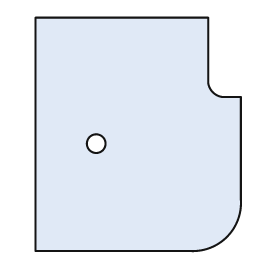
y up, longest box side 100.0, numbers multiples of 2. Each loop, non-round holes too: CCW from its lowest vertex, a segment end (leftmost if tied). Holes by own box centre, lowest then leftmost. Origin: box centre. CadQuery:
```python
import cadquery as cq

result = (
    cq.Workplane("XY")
    .moveTo(-44.0, -50.0)
    .lineTo(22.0, -50.0)
    .threePointArc((38.0, -44.0), (44.0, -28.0))
    .lineTo(44.0, 16.0)
    .lineTo(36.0, 16.0)
    .threePointArc((32.0, 18.0), (30.0, 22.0))
    .lineTo(30.0, 50.0)
    .lineTo(-44.0, 50.0)
    .close()
    .moveTo(-18.0, -4.0)
    .circle(4.0)
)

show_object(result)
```